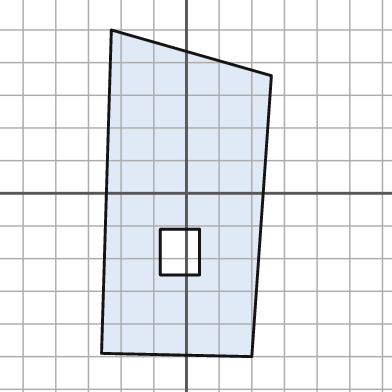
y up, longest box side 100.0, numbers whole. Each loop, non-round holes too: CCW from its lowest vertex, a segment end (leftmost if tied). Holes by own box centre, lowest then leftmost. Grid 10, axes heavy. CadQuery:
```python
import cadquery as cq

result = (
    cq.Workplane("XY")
    .moveTo(20.0, -50.0)
    .lineTo(26.0, 36.0)
    .lineTo(-23.0, 50.0)
    .lineTo(-26.0, -49.0)
    .close()
    .moveTo(-8.0, -25.0)
    .lineTo(4.0, -25.0)
    .lineTo(4.0, -11.0)
    .lineTo(-8.0, -11.0)
    .close()
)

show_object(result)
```